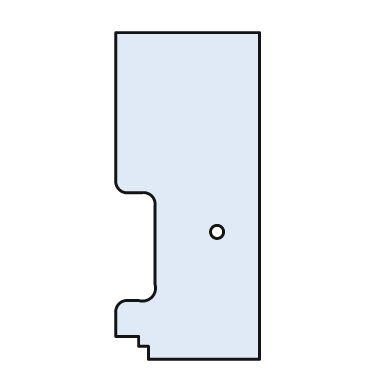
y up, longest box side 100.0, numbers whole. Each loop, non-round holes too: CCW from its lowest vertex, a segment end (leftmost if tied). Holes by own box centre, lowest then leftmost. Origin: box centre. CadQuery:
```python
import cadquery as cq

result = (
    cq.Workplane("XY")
    .moveTo(-12.0, -50.0)
    .lineTo(22.0, -50.0)
    .lineTo(22.0, 50.0)
    .lineTo(-22.0, 50.0)
    .lineTo(-22.0, 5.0)
    .threePointArc((-21.0, 2.0), (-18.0, 1.0))
    .lineTo(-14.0, 1.0)
    .threePointArc((-11.0, 0.0), (-10.0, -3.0))
    .lineTo(-10.0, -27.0)
    .threePointArc((-11.0, -31.0), (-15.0, -32.0))
    .lineTo(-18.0, -32.0)
    .threePointArc((-21.0, -33.0), (-22.0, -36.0))
    .lineTo(-22.0, -43.0)
    .lineTo(-15.0, -43.0)
    .lineTo(-15.0, -46.0)
    .lineTo(-12.0, -46.0)
    .close()
    .moveTo(9.0, -11.0)
    .circle(2.0)
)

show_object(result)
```